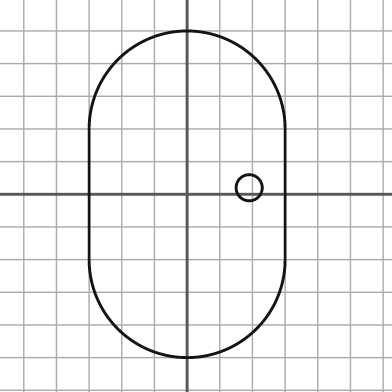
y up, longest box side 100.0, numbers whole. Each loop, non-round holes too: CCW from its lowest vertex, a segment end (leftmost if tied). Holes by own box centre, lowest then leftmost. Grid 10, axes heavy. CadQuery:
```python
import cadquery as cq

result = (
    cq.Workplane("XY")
    .moveTo(-30.0, -20.0)
    .threePointArc((0.0, -50.0), (30.0, -20.0))
    .lineTo(30.0, 20.0)
    .threePointArc((0.0, 50.0), (-30.0, 20.0))
    .close()
    .moveTo(19.0, 2.0)
    .circle(4.0)
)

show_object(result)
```